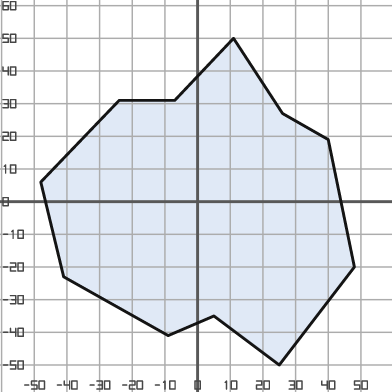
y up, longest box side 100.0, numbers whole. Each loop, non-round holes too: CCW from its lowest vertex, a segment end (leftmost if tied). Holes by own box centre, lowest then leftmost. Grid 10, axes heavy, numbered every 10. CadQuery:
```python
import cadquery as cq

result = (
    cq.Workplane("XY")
    .moveTo(25.0, -50.0)
    .lineTo(48.0, -20.0)
    .lineTo(40.0, 19.0)
    .lineTo(26.0, 27.0)
    .lineTo(11.0, 50.0)
    .lineTo(-7.0, 31.0)
    .lineTo(-24.0, 31.0)
    .lineTo(-48.0, 6.0)
    .lineTo(-41.0, -23.0)
    .lineTo(-9.0, -41.0)
    .lineTo(5.0, -35.0)
    .close()
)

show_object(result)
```